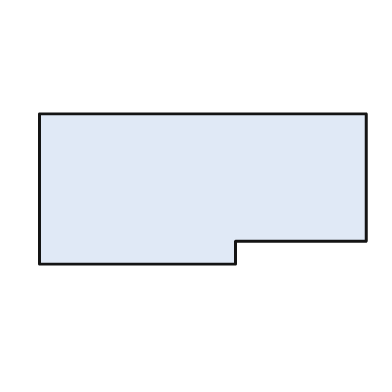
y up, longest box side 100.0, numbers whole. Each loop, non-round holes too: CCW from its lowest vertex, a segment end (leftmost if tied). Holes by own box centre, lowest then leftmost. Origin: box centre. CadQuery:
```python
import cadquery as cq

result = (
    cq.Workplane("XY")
    .moveTo(-50.0, -23.0)
    .lineTo(10.0, -23.0)
    .lineTo(10.0, -16.0)
    .lineTo(50.0, -16.0)
    .lineTo(50.0, 23.0)
    .lineTo(-50.0, 23.0)
    .close()
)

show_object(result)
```